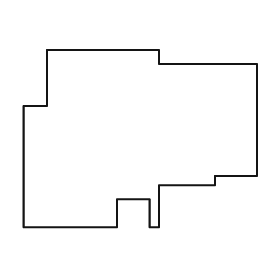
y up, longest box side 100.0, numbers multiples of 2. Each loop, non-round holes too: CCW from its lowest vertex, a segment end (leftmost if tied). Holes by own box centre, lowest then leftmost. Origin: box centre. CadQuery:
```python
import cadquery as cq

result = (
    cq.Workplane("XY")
    .moveTo(-50.0, -38.0)
    .lineTo(-10.0, -38.0)
    .lineTo(-10.0, -26.0)
    .lineTo(4.0, -26.0)
    .lineTo(4.0, -38.0)
    .lineTo(8.0, -38.0)
    .lineTo(8.0, -20.0)
    .lineTo(32.0, -20.0)
    .lineTo(32.0, -16.0)
    .lineTo(50.0, -16.0)
    .lineTo(50.0, 32.0)
    .lineTo(8.0, 32.0)
    .lineTo(8.0, 38.0)
    .lineTo(-40.0, 38.0)
    .lineTo(-40.0, 14.0)
    .lineTo(-50.0, 14.0)
    .close()
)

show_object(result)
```